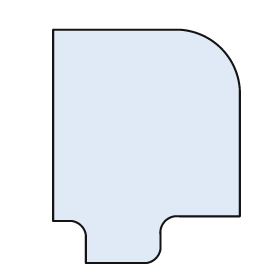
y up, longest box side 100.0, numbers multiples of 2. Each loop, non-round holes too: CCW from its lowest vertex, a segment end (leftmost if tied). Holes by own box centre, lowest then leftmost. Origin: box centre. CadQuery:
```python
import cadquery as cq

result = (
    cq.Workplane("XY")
    .moveTo(-26.0, -50.0)
    .lineTo(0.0, -50.0)
    .threePointArc((4.0, -48.0), (6.0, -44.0))
    .lineTo(6.0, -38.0)
    .threePointArc((8.0, -32.0), (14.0, -30.0))
    .lineTo(40.0, -30.0)
    .lineTo(40.0, 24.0)
    .threePointArc((32.0, 42.0), (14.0, 50.0))
    .lineTo(-40.0, 50.0)
    .lineTo(-40.0, -32.0)
    .lineTo(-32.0, -32.0)
    .threePointArc((-28.0, -34.0), (-26.0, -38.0))
    .close()
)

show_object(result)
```